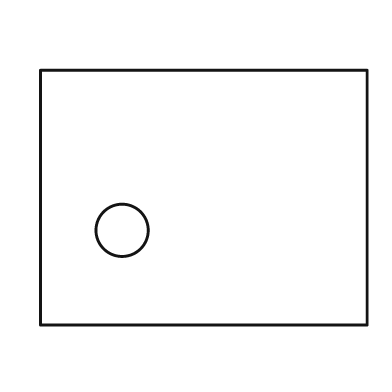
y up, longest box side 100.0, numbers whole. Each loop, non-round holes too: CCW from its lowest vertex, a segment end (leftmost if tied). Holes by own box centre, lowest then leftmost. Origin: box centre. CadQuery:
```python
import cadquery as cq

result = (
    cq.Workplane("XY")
    .moveTo(-50.0, -39.0)
    .lineTo(50.0, -39.0)
    .lineTo(50.0, 39.0)
    .lineTo(-50.0, 39.0)
    .close()
    .moveTo(-25.0, -10.0)
    .circle(8.0)
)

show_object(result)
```